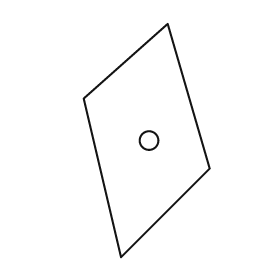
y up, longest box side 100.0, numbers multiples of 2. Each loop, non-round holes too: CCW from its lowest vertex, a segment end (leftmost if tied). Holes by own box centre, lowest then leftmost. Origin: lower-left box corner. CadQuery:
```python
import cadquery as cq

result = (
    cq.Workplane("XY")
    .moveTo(16.0, 0.0)
    .lineTo(54.0, 38.0)
    .lineTo(36.0, 100.0)
    .lineTo(0.0, 68.0)
    .close()
    .moveTo(28.0, 50.0)
    .circle(4.0)
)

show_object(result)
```